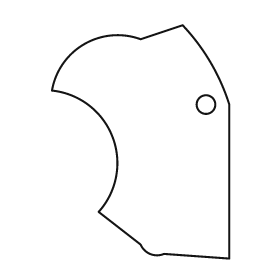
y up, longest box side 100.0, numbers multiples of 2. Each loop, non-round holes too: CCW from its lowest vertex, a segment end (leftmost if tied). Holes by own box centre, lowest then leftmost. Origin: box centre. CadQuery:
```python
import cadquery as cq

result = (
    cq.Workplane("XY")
    .moveTo(38.0, -50.0)
    .lineTo(38.0, 16.0)
    .threePointArc((30.0, 34.0), (18.0, 50.0))
    .lineTo(0.0, 44.0)
    .threePointArc((-24.0, 42.0), (-38.0, 22.0))
    .threePointArc((-12.0, 2.0), (-18.0, -30.0))
    .lineTo(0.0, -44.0)
    .threePointArc((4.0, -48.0), (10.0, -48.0))
    .close()
    .moveTo(28.0, 16.0)
    .circle(4.0)
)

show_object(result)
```